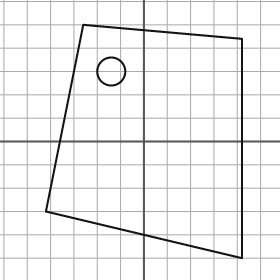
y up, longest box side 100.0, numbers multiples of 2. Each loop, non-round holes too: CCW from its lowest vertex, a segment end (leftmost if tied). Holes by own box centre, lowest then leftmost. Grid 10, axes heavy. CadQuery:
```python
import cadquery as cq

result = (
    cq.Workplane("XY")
    .moveTo(42.0, -50.0)
    .lineTo(42.0, 44.0)
    .lineTo(-26.0, 50.0)
    .lineTo(-42.0, -30.0)
    .close()
    .moveTo(-14.0, 30.0)
    .circle(6.0)
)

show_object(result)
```